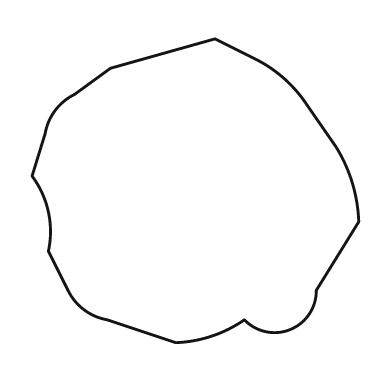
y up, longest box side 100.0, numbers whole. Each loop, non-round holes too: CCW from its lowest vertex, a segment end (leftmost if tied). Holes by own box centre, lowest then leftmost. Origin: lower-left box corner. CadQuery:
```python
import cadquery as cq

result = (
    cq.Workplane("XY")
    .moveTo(44.0, 0.0)
    .threePointArc((55.0, 2.0), (65.0, 7.0))
    .threePointArc((79.0, 4.0), (87.0, 16.0))
    .lineTo(100.0, 37.0)
    .threePointArc((98.0, 49.0), (93.0, 60.0))
    .lineTo(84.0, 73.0)
    .threePointArc((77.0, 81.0), (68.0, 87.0))
    .lineTo(56.0, 93.0)
    .lineTo(24.0, 84.0)
    .lineTo(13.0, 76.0)
    .threePointArc((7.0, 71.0), (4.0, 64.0))
    .lineTo(0.0, 51.0)
    .threePointArc((5.0, 40.0), (5.0, 28.0))
    .lineTo(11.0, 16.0)
    .threePointArc((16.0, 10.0), (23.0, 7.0))
    .close()
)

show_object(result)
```